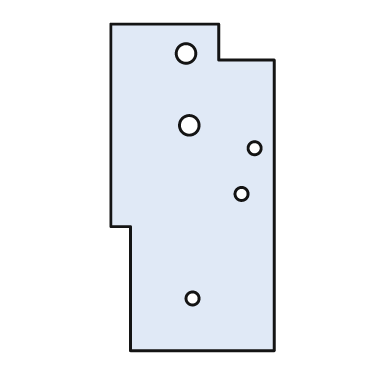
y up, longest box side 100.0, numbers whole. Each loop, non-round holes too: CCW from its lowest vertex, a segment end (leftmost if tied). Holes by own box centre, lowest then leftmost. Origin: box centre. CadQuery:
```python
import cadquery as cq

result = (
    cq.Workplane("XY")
    .moveTo(-19.0, -50.0)
    .lineTo(25.0, -50.0)
    .lineTo(25.0, 39.0)
    .lineTo(8.0, 39.0)
    .lineTo(8.0, 50.0)
    .lineTo(-25.0, 50.0)
    .lineTo(-25.0, -12.0)
    .lineTo(-19.0, -12.0)
    .close()
    .moveTo(0.0, -34.0)
    .circle(2.0)
    .moveTo(15.0, -2.0)
    .circle(2.0)
    .moveTo(19.0, 12.0)
    .circle(2.0)
    .moveTo(-1.0, 19.0)
    .circle(3.0)
    .moveTo(-2.0, 41.0)
    .circle(3.0)
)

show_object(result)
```